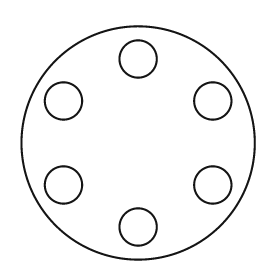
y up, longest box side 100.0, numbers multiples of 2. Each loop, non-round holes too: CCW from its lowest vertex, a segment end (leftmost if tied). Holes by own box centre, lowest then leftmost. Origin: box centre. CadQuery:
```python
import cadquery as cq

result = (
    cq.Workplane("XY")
    .moveTo(0.0, 0.0)
    .circle(50.0)
    .moveTo(0.0, -36.0)
    .circle(8.0)
    .moveTo(-32.0, -18.0)
    .circle(8.0)
    .moveTo(32.0, -18.0)
    .circle(8.0)
    .moveTo(-32.0, 18.0)
    .circle(8.0)
    .moveTo(32.0, 18.0)
    .circle(8.0)
    .moveTo(0.0, 36.0)
    .circle(8.0)
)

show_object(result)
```